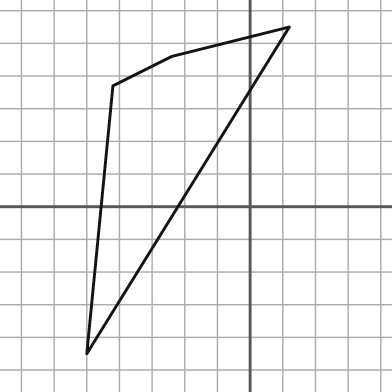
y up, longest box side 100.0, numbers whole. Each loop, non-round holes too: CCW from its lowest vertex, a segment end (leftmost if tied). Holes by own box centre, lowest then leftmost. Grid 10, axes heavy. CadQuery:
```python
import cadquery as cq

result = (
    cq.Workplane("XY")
    .moveTo(-50.0, -45.0)
    .lineTo(12.0, 55.0)
    .lineTo(-24.0, 46.0)
    .lineTo(-42.0, 37.0)
    .close()
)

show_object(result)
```